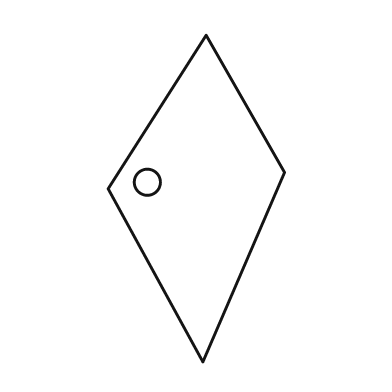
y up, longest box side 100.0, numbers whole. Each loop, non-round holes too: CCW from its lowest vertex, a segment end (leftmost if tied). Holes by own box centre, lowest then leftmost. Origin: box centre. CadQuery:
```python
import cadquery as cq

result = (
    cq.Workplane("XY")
    .moveTo(2.0, -50.0)
    .lineTo(27.0, 8.0)
    .lineTo(3.0, 50.0)
    .lineTo(-27.0, 3.0)
    .close()
    .moveTo(-15.0, 5.0)
    .circle(4.0)
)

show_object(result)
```